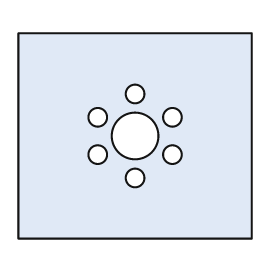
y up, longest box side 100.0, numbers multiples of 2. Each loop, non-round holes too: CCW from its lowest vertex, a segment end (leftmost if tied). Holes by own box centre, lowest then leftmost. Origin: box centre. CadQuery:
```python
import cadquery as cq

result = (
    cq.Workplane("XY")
    .moveTo(-50.0, -44.0)
    .lineTo(50.0, -44.0)
    .lineTo(50.0, 44.0)
    .lineTo(-50.0, 44.0)
    .close()
    .moveTo(0.0, -18.0)
    .circle(4.0)
    .moveTo(-16.0, -8.0)
    .circle(4.0)
    .moveTo(16.0, -8.0)
    .circle(4.0)
    .moveTo(0.0, 0.0)
    .circle(10.0)
    .moveTo(-16.0, 8.0)
    .circle(4.0)
    .moveTo(16.0, 8.0)
    .circle(4.0)
    .moveTo(0.0, 18.0)
    .circle(4.0)
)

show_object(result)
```